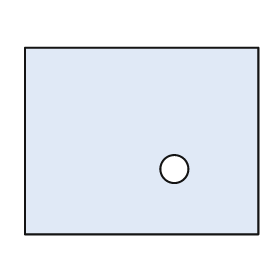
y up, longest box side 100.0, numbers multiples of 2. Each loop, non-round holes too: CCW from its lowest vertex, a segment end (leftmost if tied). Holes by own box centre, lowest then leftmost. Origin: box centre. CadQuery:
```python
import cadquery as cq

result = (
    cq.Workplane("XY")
    .moveTo(-50.0, -40.0)
    .lineTo(50.0, -40.0)
    .lineTo(50.0, 40.0)
    .lineTo(-50.0, 40.0)
    .close()
    .moveTo(14.0, -12.0)
    .circle(6.0)
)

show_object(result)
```